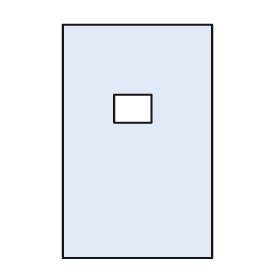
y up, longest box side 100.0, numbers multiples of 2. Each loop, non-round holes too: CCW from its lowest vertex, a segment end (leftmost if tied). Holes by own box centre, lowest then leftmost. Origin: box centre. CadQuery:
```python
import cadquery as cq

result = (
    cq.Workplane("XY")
    .moveTo(-32.0, -50.0)
    .lineTo(32.0, -50.0)
    .lineTo(32.0, 50.0)
    .lineTo(-32.0, 50.0)
    .close()
    .moveTo(-10.0, 8.0)
    .lineTo(6.0, 8.0)
    .lineTo(6.0, 20.0)
    .lineTo(-10.0, 20.0)
    .close()
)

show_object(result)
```